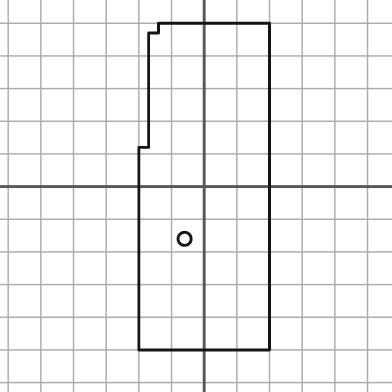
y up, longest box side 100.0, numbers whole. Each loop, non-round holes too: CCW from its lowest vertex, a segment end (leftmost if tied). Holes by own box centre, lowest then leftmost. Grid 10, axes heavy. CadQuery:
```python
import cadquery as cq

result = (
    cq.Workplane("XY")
    .moveTo(-20.0, -50.0)
    .lineTo(20.0, -50.0)
    .lineTo(20.0, 50.0)
    .lineTo(-14.0, 50.0)
    .lineTo(-14.0, 47.0)
    .lineTo(-17.0, 47.0)
    .lineTo(-17.0, 12.0)
    .lineTo(-20.0, 12.0)
    .close()
    .moveTo(-6.0, -16.0)
    .circle(2.0)
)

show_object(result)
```